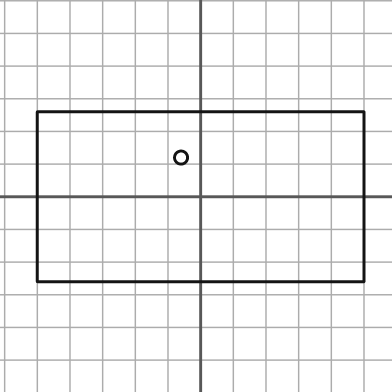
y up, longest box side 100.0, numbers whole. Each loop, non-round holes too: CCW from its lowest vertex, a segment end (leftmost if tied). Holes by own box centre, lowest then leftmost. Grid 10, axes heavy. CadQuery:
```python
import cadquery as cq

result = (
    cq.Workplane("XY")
    .moveTo(-50.0, -26.0)
    .lineTo(50.0, -26.0)
    .lineTo(50.0, 26.0)
    .lineTo(-50.0, 26.0)
    .close()
    .moveTo(-6.0, 12.0)
    .circle(2.0)
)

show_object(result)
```